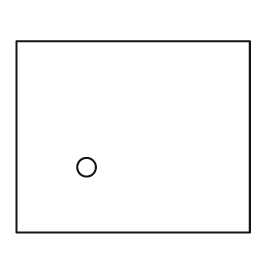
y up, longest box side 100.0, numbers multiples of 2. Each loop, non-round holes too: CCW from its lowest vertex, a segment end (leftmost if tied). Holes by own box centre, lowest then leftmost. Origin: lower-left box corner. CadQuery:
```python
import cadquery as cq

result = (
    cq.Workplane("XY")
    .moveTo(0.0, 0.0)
    .lineTo(100.0, 0.0)
    .lineTo(100.0, 82.0)
    .lineTo(0.0, 82.0)
    .close()
    .moveTo(30.0, 28.0)
    .circle(4.0)
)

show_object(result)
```